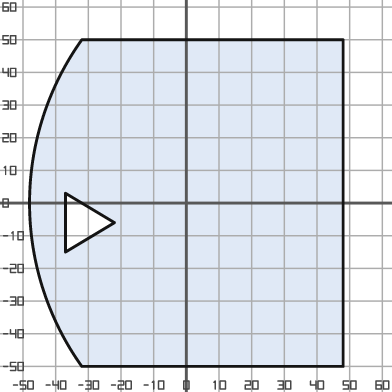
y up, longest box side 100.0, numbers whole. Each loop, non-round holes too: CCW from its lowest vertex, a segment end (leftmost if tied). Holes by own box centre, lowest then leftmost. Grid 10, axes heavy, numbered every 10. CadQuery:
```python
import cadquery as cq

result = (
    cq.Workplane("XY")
    .moveTo(-32.0, -50.0)
    .lineTo(48.0, -50.0)
    .lineTo(48.0, 50.0)
    .lineTo(-32.0, 50.0)
    .threePointArc((-48.0, 0.0), (-32.0, -50.0))
    .close()
    .moveTo(-37.0, -15.0)
    .lineTo(-22.0, -6.0)
    .lineTo(-37.0, 3.0)
    .close()
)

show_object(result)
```